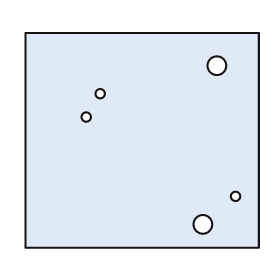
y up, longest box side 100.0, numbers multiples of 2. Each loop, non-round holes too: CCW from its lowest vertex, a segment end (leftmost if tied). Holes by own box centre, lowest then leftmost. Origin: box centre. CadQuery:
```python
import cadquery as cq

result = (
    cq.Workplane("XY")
    .moveTo(-50.0, -46.0)
    .lineTo(50.0, -46.0)
    .lineTo(50.0, 46.0)
    .lineTo(-50.0, 46.0)
    .close()
    .moveTo(26.0, -36.0)
    .circle(4.0)
    .moveTo(40.0, -24.0)
    .circle(2.0)
    .moveTo(-24.0, 10.0)
    .circle(2.0)
    .moveTo(-18.0, 20.0)
    .circle(2.0)
    .moveTo(32.0, 32.0)
    .circle(4.0)
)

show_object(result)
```